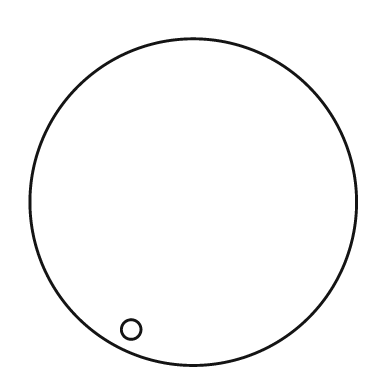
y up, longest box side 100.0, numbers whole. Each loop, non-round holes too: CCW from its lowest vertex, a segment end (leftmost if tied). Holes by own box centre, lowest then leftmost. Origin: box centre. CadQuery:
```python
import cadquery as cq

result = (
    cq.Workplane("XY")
    .moveTo(0.0, 0.0)
    .circle(50.0)
    .moveTo(-19.0, -39.0)
    .circle(3.0)
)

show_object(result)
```